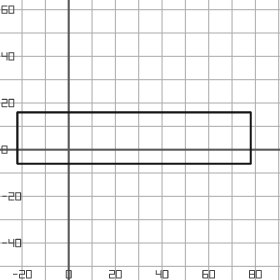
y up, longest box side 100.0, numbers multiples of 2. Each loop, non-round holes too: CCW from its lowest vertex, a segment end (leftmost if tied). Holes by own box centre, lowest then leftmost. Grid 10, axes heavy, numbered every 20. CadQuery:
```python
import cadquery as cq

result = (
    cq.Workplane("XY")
    .moveTo(-22.0, -6.0)
    .lineTo(78.0, -6.0)
    .lineTo(78.0, 16.0)
    .lineTo(-22.0, 16.0)
    .close()
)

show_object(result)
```